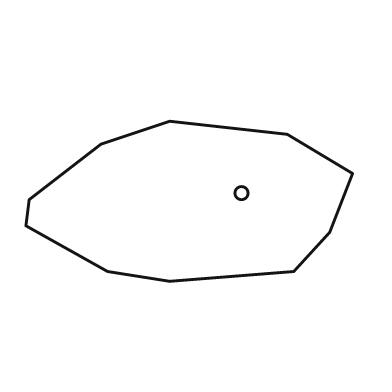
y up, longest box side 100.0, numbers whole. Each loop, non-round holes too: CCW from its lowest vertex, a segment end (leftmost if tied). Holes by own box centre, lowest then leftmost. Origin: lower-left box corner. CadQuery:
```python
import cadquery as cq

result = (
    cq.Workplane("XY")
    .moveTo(44.0, 0.0)
    .lineTo(82.0, 3.0)
    .lineTo(93.0, 15.0)
    .lineTo(100.0, 33.0)
    .lineTo(80.0, 45.0)
    .lineTo(44.0, 49.0)
    .lineTo(23.0, 42.0)
    .lineTo(1.0, 25.0)
    .lineTo(0.0, 17.0)
    .lineTo(25.0, 3.0)
    .close()
    .moveTo(66.0, 27.0)
    .circle(2.0)
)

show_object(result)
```